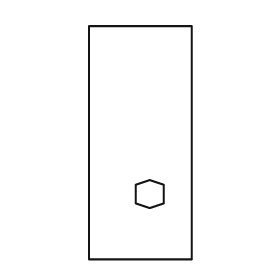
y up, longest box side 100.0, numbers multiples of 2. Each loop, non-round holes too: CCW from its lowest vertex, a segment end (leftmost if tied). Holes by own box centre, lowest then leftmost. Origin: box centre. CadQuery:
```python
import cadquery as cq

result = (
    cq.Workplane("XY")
    .moveTo(-22.0, -50.0)
    .lineTo(22.0, -50.0)
    .lineTo(22.0, 50.0)
    .lineTo(-22.0, 50.0)
    .close()
    .moveTo(4.0, -28.0)
    .lineTo(10.0, -26.0)
    .lineTo(10.0, -18.0)
    .lineTo(4.0, -16.0)
    .lineTo(-2.0, -18.0)
    .lineTo(-2.0, -26.0)
    .close()
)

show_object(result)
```